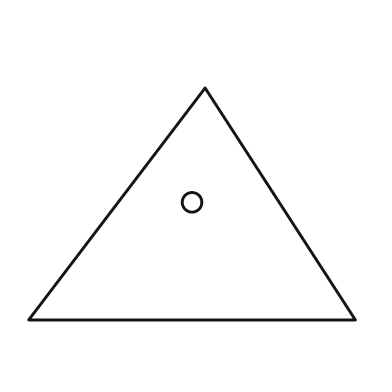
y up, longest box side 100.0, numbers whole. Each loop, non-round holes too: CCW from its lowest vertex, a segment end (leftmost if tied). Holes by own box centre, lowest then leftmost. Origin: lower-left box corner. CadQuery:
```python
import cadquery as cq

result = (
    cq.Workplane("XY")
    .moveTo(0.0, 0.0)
    .lineTo(100.0, 0.0)
    .lineTo(54.0, 71.0)
    .close()
    .moveTo(50.0, 36.0)
    .circle(3.0)
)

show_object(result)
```